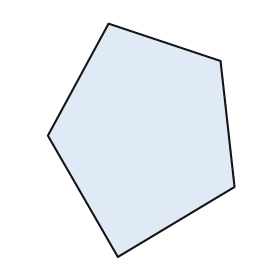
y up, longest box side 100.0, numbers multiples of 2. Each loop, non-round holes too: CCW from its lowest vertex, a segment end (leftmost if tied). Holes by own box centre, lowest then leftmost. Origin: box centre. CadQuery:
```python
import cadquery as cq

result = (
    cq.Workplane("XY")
    .moveTo(-10.0, -50.0)
    .lineTo(40.0, -20.0)
    .lineTo(34.0, 34.0)
    .lineTo(-14.0, 50.0)
    .lineTo(-40.0, 2.0)
    .close()
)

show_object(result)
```